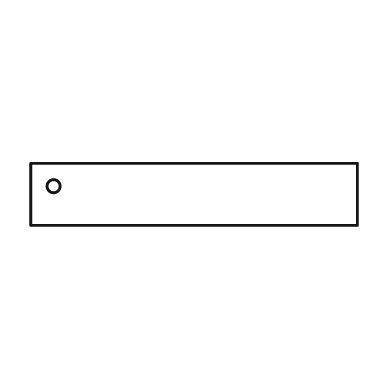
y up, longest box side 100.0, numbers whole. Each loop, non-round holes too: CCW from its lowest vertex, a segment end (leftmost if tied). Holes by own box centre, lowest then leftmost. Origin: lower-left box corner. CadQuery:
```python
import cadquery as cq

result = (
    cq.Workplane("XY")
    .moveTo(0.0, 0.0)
    .lineTo(100.0, 0.0)
    .lineTo(100.0, 19.0)
    .lineTo(0.0, 19.0)
    .close()
    .moveTo(7.0, 12.0)
    .circle(2.0)
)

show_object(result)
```